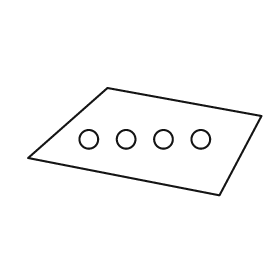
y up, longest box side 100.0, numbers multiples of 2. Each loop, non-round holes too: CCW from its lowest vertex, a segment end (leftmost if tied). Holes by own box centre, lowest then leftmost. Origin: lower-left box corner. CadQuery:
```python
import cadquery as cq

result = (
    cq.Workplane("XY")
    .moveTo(82.0, 0.0)
    .lineTo(100.0, 34.0)
    .lineTo(34.0, 46.0)
    .lineTo(0.0, 16.0)
    .close()
    .moveTo(26.0, 24.0)
    .circle(4.0)
    .moveTo(42.0, 24.0)
    .circle(4.0)
    .moveTo(58.0, 24.0)
    .circle(4.0)
    .moveTo(74.0, 24.0)
    .circle(4.0)
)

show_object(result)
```